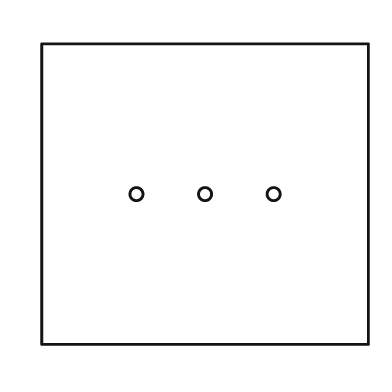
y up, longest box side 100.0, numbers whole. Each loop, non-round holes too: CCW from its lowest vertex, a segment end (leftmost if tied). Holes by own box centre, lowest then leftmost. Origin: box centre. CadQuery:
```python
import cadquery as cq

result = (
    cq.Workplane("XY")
    .moveTo(-50.0, -46.0)
    .lineTo(50.0, -46.0)
    .lineTo(50.0, 46.0)
    .lineTo(-50.0, 46.0)
    .close()
    .moveTo(-21.0, 0.0)
    .circle(2.0)
    .moveTo(0.0, 0.0)
    .circle(2.0)
    .moveTo(21.0, 0.0)
    .circle(2.0)
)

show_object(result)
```